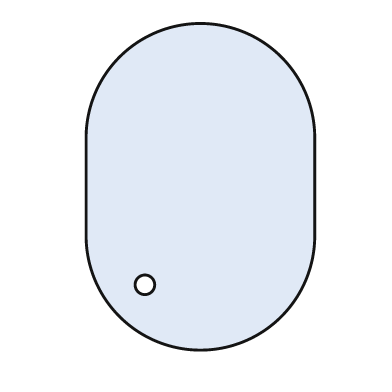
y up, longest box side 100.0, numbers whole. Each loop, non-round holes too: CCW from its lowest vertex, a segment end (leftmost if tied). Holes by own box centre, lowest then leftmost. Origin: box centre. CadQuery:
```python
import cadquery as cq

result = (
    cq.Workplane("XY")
    .moveTo(-35.0, -15.0)
    .threePointArc((0.0, -50.0), (35.0, -15.0))
    .lineTo(35.0, 15.0)
    .threePointArc((0.0, 50.0), (-35.0, 15.0))
    .close()
    .moveTo(-17.0, -30.0)
    .circle(3.0)
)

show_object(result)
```